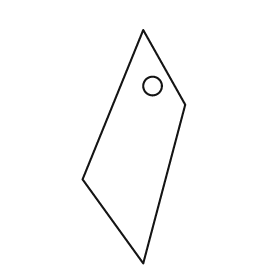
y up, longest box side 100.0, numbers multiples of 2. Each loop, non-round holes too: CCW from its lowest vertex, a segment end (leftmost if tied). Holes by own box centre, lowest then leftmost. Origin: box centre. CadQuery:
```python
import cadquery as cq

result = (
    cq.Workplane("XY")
    .moveTo(4.0, -50.0)
    .lineTo(22.0, 18.0)
    .lineTo(4.0, 50.0)
    .lineTo(-22.0, -14.0)
    .close()
    .moveTo(8.0, 26.0)
    .circle(4.0)
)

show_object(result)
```